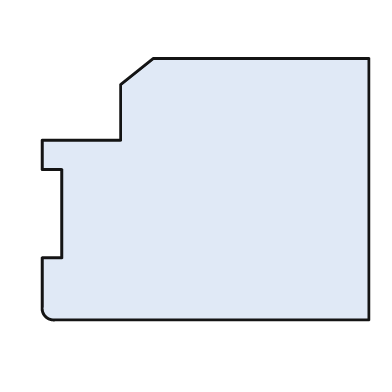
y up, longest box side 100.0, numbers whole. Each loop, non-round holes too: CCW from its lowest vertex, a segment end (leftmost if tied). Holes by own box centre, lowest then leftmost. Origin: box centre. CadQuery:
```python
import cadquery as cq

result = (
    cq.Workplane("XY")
    .moveTo(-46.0, -40.0)
    .lineTo(50.0, -40.0)
    .lineTo(50.0, 40.0)
    .lineTo(-16.0, 40.0)
    .lineTo(-26.0, 32.0)
    .lineTo(-26.0, 15.0)
    .lineTo(-50.0, 15.0)
    .lineTo(-50.0, 6.0)
    .lineTo(-44.0, 6.0)
    .lineTo(-44.0, -21.0)
    .lineTo(-50.0, -21.0)
    .lineTo(-50.0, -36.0)
    .threePointArc((-49.0, -39.0), (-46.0, -40.0))
    .close()
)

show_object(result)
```